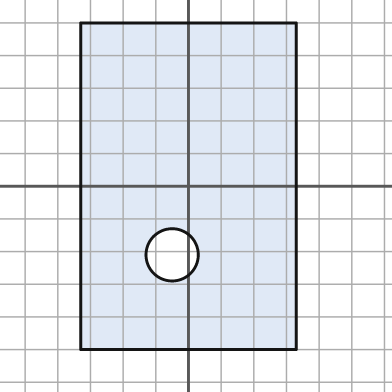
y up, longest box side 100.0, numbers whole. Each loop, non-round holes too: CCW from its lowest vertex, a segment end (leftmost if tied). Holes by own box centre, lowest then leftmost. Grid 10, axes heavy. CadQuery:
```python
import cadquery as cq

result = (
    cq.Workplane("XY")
    .moveTo(-33.0, -50.0)
    .lineTo(33.0, -50.0)
    .lineTo(33.0, 50.0)
    .lineTo(-33.0, 50.0)
    .close()
    .moveTo(-5.0, -21.0)
    .circle(8.0)
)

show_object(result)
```